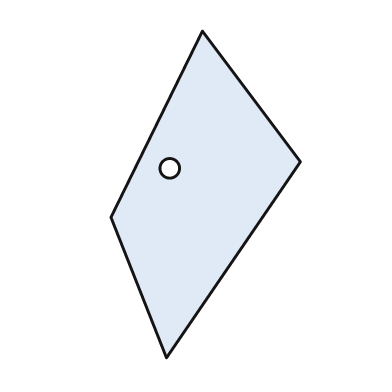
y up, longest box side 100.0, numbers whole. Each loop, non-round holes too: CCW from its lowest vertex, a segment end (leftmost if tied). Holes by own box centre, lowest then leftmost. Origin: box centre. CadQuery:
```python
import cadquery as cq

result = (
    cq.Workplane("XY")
    .moveTo(-12.0, -50.0)
    .lineTo(29.0, 10.0)
    .lineTo(-1.0, 50.0)
    .lineTo(-29.0, -7.0)
    .close()
    .moveTo(-11.0, 8.0)
    .circle(3.0)
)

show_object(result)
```